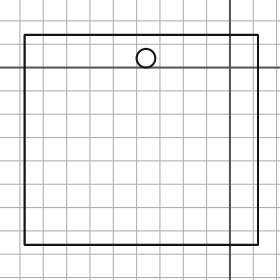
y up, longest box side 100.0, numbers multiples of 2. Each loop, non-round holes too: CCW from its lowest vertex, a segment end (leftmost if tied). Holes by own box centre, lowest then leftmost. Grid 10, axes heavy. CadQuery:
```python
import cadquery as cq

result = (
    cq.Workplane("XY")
    .moveTo(-88.0, -76.0)
    .lineTo(12.0, -76.0)
    .lineTo(12.0, 14.0)
    .lineTo(-88.0, 14.0)
    .close()
    .moveTo(-36.0, 4.0)
    .circle(4.0)
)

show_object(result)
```